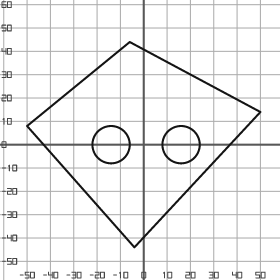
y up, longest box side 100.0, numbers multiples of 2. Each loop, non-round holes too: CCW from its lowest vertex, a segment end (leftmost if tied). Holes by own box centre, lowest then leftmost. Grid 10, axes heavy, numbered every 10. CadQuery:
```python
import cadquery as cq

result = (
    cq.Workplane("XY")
    .moveTo(-4.0, -44.0)
    .lineTo(50.0, 14.0)
    .lineTo(-6.0, 44.0)
    .lineTo(-50.0, 8.0)
    .close()
    .moveTo(-14.0, 0.0)
    .circle(8.0)
    .moveTo(16.0, 0.0)
    .circle(8.0)
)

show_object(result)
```